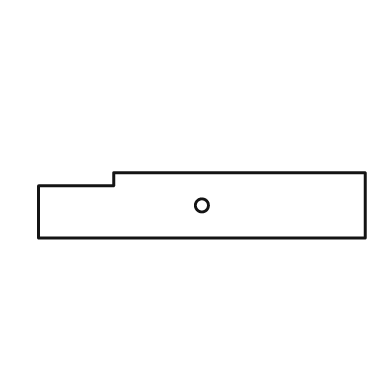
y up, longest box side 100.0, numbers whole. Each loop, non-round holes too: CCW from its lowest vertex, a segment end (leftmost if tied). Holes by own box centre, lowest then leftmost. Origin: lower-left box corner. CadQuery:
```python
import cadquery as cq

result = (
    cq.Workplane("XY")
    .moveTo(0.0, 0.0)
    .lineTo(100.0, 0.0)
    .lineTo(100.0, 20.0)
    .lineTo(23.0, 20.0)
    .lineTo(23.0, 16.0)
    .lineTo(0.0, 16.0)
    .close()
    .moveTo(50.0, 10.0)
    .circle(2.0)
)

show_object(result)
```